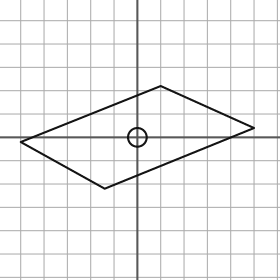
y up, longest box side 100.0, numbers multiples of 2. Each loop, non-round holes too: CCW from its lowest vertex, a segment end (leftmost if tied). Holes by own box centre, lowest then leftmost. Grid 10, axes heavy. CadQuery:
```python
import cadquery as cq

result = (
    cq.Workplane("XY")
    .moveTo(-14.0, -22.0)
    .lineTo(50.0, 4.0)
    .lineTo(10.0, 22.0)
    .lineTo(-50.0, -2.0)
    .close()
    .moveTo(0.0, 0.0)
    .circle(4.0)
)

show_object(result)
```